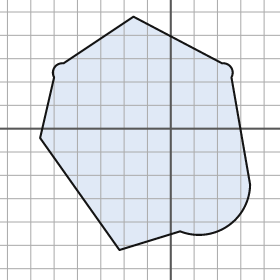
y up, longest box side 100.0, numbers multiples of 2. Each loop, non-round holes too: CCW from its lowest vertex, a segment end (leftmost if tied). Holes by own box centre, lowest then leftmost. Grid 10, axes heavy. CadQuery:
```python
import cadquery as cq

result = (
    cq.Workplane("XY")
    .moveTo(-22.0, -52.0)
    .lineTo(4.0, -44.0)
    .threePointArc((24.0, -42.0), (34.0, -24.0))
    .lineTo(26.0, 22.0)
    .threePointArc((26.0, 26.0), (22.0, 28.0))
    .lineTo(-16.0, 48.0)
    .lineTo(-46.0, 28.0)
    .threePointArc((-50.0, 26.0), (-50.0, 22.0))
    .lineTo(-56.0, -4.0)
    .close()
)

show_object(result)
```